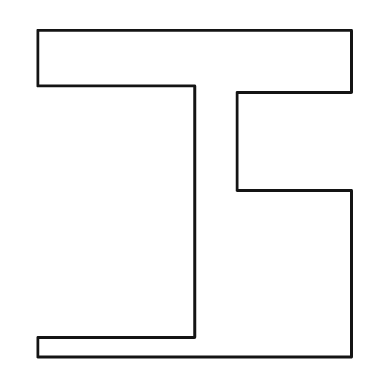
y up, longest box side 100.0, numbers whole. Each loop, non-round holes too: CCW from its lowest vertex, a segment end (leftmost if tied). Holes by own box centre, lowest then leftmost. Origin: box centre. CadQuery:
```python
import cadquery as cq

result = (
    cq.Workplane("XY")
    .moveTo(-48.0, -50.0)
    .lineTo(48.0, -50.0)
    .lineTo(48.0, 1.0)
    .lineTo(13.0, 1.0)
    .lineTo(13.0, 31.0)
    .lineTo(48.0, 31.0)
    .lineTo(48.0, 50.0)
    .lineTo(-48.0, 50.0)
    .lineTo(-48.0, 33.0)
    .lineTo(0.0, 33.0)
    .lineTo(0.0, -44.0)
    .lineTo(-48.0, -44.0)
    .close()
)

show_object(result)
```